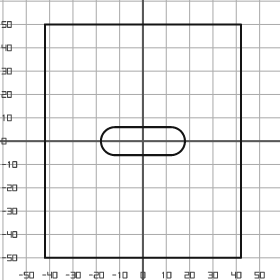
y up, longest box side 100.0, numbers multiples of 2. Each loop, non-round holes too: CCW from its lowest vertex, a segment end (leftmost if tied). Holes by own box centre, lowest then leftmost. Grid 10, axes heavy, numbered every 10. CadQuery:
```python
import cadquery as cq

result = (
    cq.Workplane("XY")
    .moveTo(-42.0, -50.0)
    .lineTo(42.0, -50.0)
    .lineTo(42.0, 50.0)
    .lineTo(-42.0, 50.0)
    .close()
    .moveTo(-12.0, -6.0)
    .lineTo(12.0, -6.0)
    .threePointArc((18.0, 0.0), (12.0, 6.0))
    .lineTo(-12.0, 6.0)
    .threePointArc((-18.0, 0.0), (-12.0, -6.0))
    .close()
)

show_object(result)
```